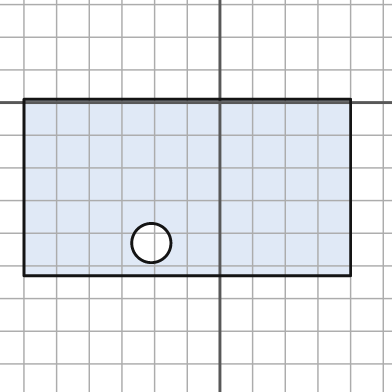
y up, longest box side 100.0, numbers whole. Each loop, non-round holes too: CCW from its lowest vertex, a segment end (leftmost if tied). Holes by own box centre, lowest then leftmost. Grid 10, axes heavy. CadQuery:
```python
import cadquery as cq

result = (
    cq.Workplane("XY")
    .moveTo(-60.0, -53.0)
    .lineTo(40.0, -53.0)
    .lineTo(40.0, 1.0)
    .lineTo(-60.0, 1.0)
    .close()
    .moveTo(-21.0, -43.0)
    .circle(6.0)
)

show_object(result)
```